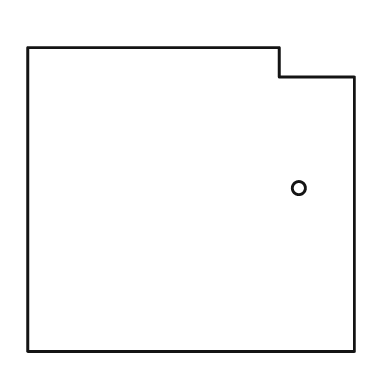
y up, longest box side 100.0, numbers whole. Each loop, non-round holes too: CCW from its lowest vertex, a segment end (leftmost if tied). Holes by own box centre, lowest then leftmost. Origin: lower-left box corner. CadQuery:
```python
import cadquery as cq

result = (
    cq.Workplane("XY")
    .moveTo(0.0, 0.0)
    .lineTo(100.0, 0.0)
    .lineTo(100.0, 84.0)
    .lineTo(77.0, 84.0)
    .lineTo(77.0, 93.0)
    .lineTo(0.0, 93.0)
    .close()
    .moveTo(83.0, 50.0)
    .circle(2.0)
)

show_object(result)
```